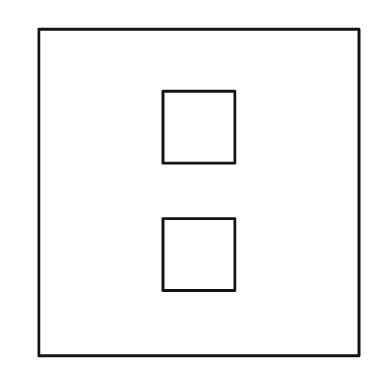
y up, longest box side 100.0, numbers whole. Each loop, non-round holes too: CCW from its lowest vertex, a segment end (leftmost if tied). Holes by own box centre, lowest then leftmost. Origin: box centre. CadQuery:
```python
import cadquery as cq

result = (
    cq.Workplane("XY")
    .moveTo(-49.0, -50.0)
    .lineTo(49.0, -50.0)
    .lineTo(49.0, 50.0)
    .lineTo(-49.0, 50.0)
    .close()
    .moveTo(-11.0, -30.0)
    .lineTo(11.0, -30.0)
    .lineTo(11.0, -8.0)
    .lineTo(-11.0, -8.0)
    .close()
    .moveTo(-11.0, 9.0)
    .lineTo(11.0, 9.0)
    .lineTo(11.0, 31.0)
    .lineTo(-11.0, 31.0)
    .close()
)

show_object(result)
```